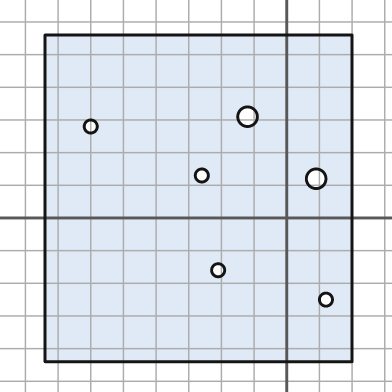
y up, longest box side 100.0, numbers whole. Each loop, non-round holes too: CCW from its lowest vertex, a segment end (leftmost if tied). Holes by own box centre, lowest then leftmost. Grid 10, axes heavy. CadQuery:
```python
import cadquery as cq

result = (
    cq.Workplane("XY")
    .moveTo(-74.0, -44.0)
    .lineTo(20.0, -44.0)
    .lineTo(20.0, 56.0)
    .lineTo(-74.0, 56.0)
    .close()
    .moveTo(12.0, -25.0)
    .circle(2.0)
    .moveTo(-21.0, -16.0)
    .circle(2.0)
    .moveTo(9.0, 12.0)
    .circle(3.0)
    .moveTo(-26.0, 13.0)
    .circle(2.0)
    .moveTo(-60.0, 28.0)
    .circle(2.0)
    .moveTo(-12.0, 31.0)
    .circle(3.0)
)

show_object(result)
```